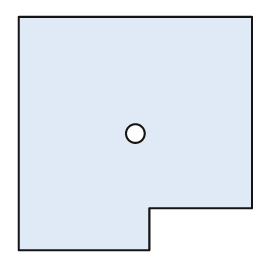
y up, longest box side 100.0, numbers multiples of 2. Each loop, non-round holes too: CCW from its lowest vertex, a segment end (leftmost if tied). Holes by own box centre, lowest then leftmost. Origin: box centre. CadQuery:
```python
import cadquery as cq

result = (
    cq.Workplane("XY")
    .moveTo(-50.0, -50.0)
    .lineTo(6.0, -50.0)
    .lineTo(6.0, -32.0)
    .lineTo(50.0, -32.0)
    .lineTo(50.0, 50.0)
    .lineTo(-50.0, 50.0)
    .close()
    .moveTo(0.0, 0.0)
    .circle(4.0)
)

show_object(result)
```